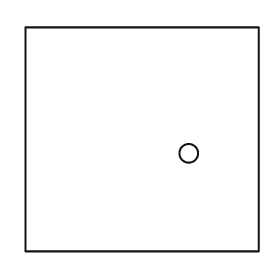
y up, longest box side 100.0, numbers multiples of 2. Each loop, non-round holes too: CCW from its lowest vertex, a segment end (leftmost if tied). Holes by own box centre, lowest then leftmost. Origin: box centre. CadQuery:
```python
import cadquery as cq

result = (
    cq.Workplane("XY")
    .moveTo(-50.0, -48.0)
    .lineTo(50.0, -48.0)
    .lineTo(50.0, 48.0)
    .lineTo(-50.0, 48.0)
    .close()
    .moveTo(20.0, -6.0)
    .circle(4.0)
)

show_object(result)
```